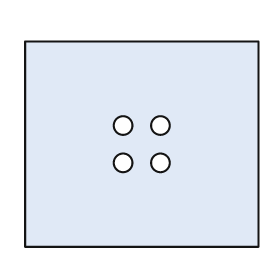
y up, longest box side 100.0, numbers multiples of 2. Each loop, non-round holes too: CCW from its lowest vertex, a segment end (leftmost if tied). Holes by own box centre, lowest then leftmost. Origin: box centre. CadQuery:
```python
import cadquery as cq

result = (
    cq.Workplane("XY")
    .moveTo(-50.0, -44.0)
    .lineTo(50.0, -44.0)
    .lineTo(50.0, 44.0)
    .lineTo(-50.0, 44.0)
    .close()
    .moveTo(-8.0, -8.0)
    .circle(4.0)
    .moveTo(8.0, -8.0)
    .circle(4.0)
    .moveTo(-8.0, 8.0)
    .circle(4.0)
    .moveTo(8.0, 8.0)
    .circle(4.0)
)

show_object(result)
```